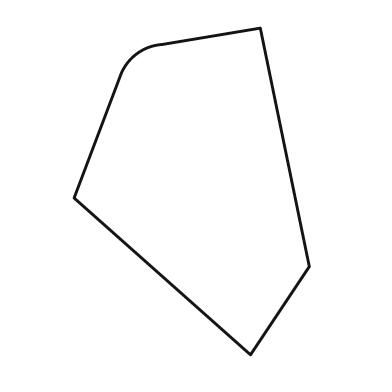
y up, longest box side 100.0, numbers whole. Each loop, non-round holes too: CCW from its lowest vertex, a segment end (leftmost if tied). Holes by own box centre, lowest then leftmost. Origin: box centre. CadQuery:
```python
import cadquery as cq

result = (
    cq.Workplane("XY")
    .moveTo(18.0, -50.0)
    .lineTo(36.0, -23.0)
    .lineTo(21.0, 50.0)
    .lineTo(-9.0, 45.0)
    .threePointArc((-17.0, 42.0), (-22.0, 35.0))
    .lineTo(-36.0, -2.0)
    .close()
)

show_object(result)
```